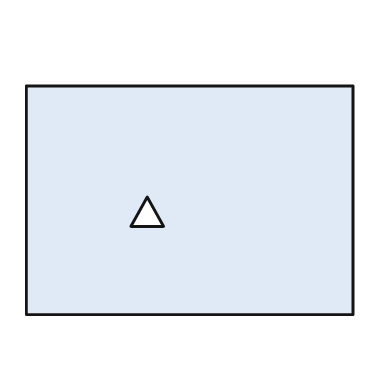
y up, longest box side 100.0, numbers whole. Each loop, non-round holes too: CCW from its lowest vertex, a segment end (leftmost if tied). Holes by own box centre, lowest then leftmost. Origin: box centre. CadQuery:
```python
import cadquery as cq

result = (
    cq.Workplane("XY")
    .moveTo(-50.0, -35.0)
    .lineTo(50.0, -35.0)
    .lineTo(50.0, 35.0)
    .lineTo(-50.0, 35.0)
    .close()
    .moveTo(-18.0, -8.0)
    .lineTo(-8.0, -8.0)
    .lineTo(-13.0, 1.0)
    .close()
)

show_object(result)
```